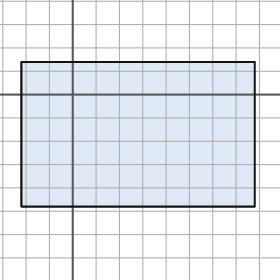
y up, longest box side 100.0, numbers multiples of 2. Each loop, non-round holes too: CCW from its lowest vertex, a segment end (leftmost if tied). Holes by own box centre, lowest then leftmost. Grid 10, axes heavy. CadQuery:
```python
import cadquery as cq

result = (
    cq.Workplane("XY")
    .moveTo(-22.0, -48.0)
    .lineTo(78.0, -48.0)
    .lineTo(78.0, 14.0)
    .lineTo(-22.0, 14.0)
    .close()
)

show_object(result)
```